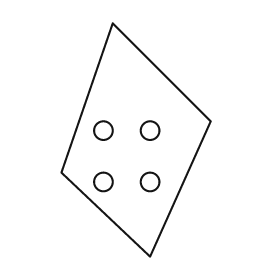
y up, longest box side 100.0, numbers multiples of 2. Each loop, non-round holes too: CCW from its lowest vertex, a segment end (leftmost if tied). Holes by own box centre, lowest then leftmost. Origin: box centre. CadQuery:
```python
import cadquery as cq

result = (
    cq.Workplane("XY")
    .moveTo(6.0, -50.0)
    .lineTo(32.0, 8.0)
    .lineTo(-10.0, 50.0)
    .lineTo(-32.0, -14.0)
    .close()
    .moveTo(-14.0, -18.0)
    .circle(4.0)
    .moveTo(6.0, -18.0)
    .circle(4.0)
    .moveTo(-14.0, 4.0)
    .circle(4.0)
    .moveTo(6.0, 4.0)
    .circle(4.0)
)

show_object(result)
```